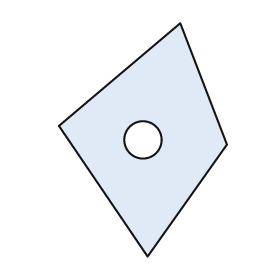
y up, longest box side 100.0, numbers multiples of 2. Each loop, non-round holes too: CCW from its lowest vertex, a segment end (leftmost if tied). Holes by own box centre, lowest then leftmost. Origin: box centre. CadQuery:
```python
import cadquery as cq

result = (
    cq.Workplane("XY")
    .moveTo(2.0, -50.0)
    .lineTo(36.0, -2.0)
    .lineTo(16.0, 50.0)
    .lineTo(-36.0, 6.0)
    .close()
    .moveTo(0.0, 0.0)
    .circle(8.0)
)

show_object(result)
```